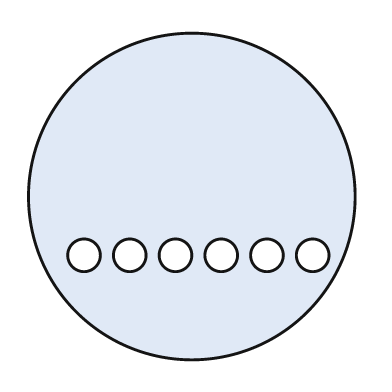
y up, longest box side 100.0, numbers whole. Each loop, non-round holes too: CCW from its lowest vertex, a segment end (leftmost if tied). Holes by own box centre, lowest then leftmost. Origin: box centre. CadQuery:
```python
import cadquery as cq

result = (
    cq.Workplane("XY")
    .moveTo(0.0, 0.0)
    .circle(50.0)
    .moveTo(-33.0, -18.0)
    .circle(5.0)
    .moveTo(-19.0, -18.0)
    .circle(5.0)
    .moveTo(-5.0, -18.0)
    .circle(5.0)
    .moveTo(9.0, -18.0)
    .circle(5.0)
    .moveTo(23.0, -18.0)
    .circle(5.0)
    .moveTo(37.0, -18.0)
    .circle(5.0)
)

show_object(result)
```